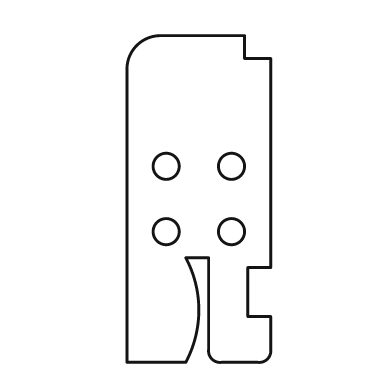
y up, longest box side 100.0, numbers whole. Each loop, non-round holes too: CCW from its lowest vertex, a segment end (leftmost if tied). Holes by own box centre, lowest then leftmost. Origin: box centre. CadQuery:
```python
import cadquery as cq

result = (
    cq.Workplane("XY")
    .moveTo(-22.0, -50.0)
    .lineTo(-4.0, -50.0)
    .threePointArc((0.0, -34.0), (-4.0, -18.0))
    .lineTo(3.0, -18.0)
    .lineTo(3.0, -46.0)
    .threePointArc((4.0, -49.0), (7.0, -50.0))
    .lineTo(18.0, -50.0)
    .threePointArc((21.0, -49.0), (22.0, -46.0))
    .lineTo(22.0, -36.0)
    .lineTo(15.0, -36.0)
    .lineTo(15.0, -21.0)
    .lineTo(22.0, -21.0)
    .lineTo(22.0, 43.0)
    .lineTo(14.0, 43.0)
    .lineTo(14.0, 50.0)
    .lineTo(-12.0, 50.0)
    .threePointArc((-19.0, 47.0), (-22.0, 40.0))
    .close()
    .moveTo(-10.0, -10.0)
    .circle(4.0)
    .moveTo(10.0, -10.0)
    .circle(4.0)
    .moveTo(-10.0, 10.0)
    .circle(4.0)
    .moveTo(10.0, 10.0)
    .circle(4.0)
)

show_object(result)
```